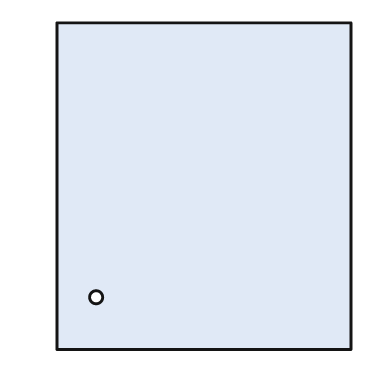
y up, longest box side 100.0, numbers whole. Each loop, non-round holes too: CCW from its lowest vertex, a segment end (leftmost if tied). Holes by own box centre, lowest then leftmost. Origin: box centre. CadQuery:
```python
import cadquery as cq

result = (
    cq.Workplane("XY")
    .moveTo(-45.0, -50.0)
    .lineTo(45.0, -50.0)
    .lineTo(45.0, 50.0)
    .lineTo(-45.0, 50.0)
    .close()
    .moveTo(-33.0, -34.0)
    .circle(2.0)
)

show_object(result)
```